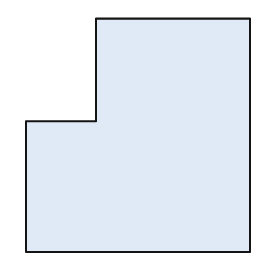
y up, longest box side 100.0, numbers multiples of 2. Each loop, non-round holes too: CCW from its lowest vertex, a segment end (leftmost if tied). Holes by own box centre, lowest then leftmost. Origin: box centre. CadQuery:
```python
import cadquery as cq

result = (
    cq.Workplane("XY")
    .moveTo(-48.0, -50.0)
    .lineTo(48.0, -50.0)
    .lineTo(48.0, 50.0)
    .lineTo(-18.0, 50.0)
    .lineTo(-18.0, 6.0)
    .lineTo(-48.0, 6.0)
    .close()
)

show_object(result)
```